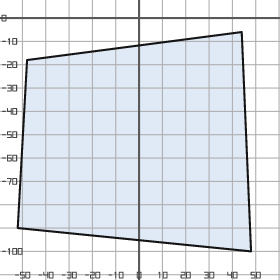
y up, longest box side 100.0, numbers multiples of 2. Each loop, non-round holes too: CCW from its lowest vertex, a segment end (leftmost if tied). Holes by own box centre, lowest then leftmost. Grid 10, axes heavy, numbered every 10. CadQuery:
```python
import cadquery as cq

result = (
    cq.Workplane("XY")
    .moveTo(48.0, -100.0)
    .lineTo(44.0, -6.0)
    .lineTo(-48.0, -18.0)
    .lineTo(-52.0, -90.0)
    .close()
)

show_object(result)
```